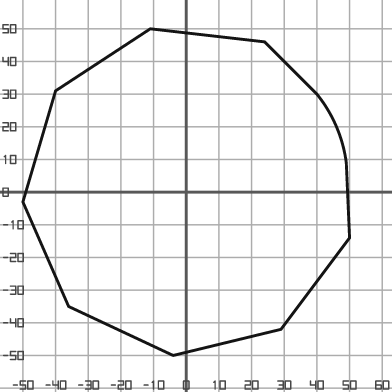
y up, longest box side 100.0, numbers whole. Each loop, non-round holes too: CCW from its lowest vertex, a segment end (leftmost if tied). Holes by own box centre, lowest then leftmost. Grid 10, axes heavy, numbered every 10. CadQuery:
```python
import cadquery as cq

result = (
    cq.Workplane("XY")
    .moveTo(-4.0, -50.0)
    .lineTo(29.0, -42.0)
    .lineTo(50.0, -14.0)
    .lineTo(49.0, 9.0)
    .threePointArc((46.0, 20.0), (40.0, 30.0))
    .lineTo(24.0, 46.0)
    .lineTo(-11.0, 50.0)
    .lineTo(-40.0, 31.0)
    .lineTo(-50.0, -3.0)
    .lineTo(-36.0, -35.0)
    .close()
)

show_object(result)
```